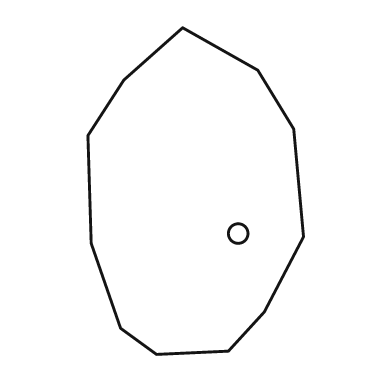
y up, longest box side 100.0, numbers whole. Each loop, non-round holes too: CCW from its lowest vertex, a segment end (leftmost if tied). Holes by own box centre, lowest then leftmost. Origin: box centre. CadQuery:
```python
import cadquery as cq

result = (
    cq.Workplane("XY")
    .moveTo(-12.0, -50.0)
    .lineTo(10.0, -49.0)
    .lineTo(21.0, -37.0)
    .lineTo(33.0, -14.0)
    .lineTo(30.0, 19.0)
    .lineTo(19.0, 37.0)
    .lineTo(-4.0, 50.0)
    .lineTo(-22.0, 34.0)
    .lineTo(-33.0, 17.0)
    .lineTo(-32.0, -16.0)
    .lineTo(-23.0, -42.0)
    .close()
    .moveTo(13.0, -13.0)
    .circle(3.0)
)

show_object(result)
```